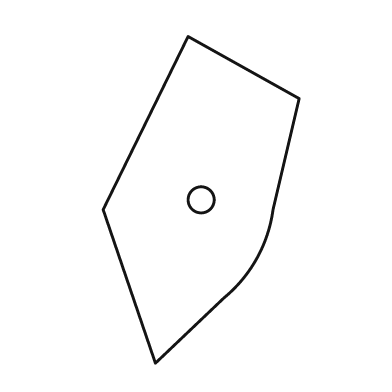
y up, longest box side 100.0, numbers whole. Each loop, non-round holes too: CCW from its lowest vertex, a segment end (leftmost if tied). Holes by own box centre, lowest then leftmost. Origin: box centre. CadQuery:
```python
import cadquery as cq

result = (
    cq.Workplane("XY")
    .moveTo(-14.0, -50.0)
    .lineTo(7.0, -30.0)
    .threePointArc((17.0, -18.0), (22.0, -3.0))
    .lineTo(30.0, 31.0)
    .lineTo(-4.0, 50.0)
    .lineTo(-30.0, -3.0)
    .close()
    .moveTo(0.0, 0.0)
    .circle(4.0)
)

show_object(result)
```